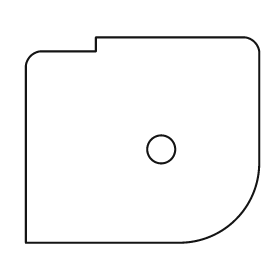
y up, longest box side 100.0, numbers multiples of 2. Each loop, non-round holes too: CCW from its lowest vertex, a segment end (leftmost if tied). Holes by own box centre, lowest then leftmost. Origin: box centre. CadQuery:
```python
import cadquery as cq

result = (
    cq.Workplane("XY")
    .moveTo(-50.0, -44.0)
    .lineTo(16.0, -44.0)
    .threePointArc((40.0, -34.0), (50.0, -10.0))
    .lineTo(50.0, 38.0)
    .threePointArc((48.0, 42.0), (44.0, 44.0))
    .lineTo(-20.0, 44.0)
    .lineTo(-20.0, 38.0)
    .lineTo(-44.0, 38.0)
    .threePointArc((-48.0, 36.0), (-50.0, 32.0))
    .close()
    .moveTo(8.0, -4.0)
    .circle(6.0)
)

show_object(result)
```